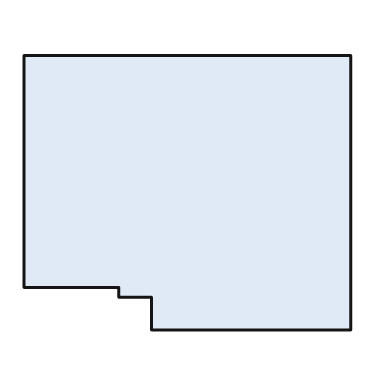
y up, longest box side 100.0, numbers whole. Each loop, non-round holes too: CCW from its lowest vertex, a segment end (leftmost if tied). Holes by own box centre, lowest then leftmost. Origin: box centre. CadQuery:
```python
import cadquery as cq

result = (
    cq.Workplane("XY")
    .moveTo(-11.0, -42.0)
    .lineTo(50.0, -42.0)
    .lineTo(50.0, 42.0)
    .lineTo(-50.0, 42.0)
    .lineTo(-50.0, -29.0)
    .lineTo(-21.0, -29.0)
    .lineTo(-21.0, -32.0)
    .lineTo(-11.0, -32.0)
    .close()
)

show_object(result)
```